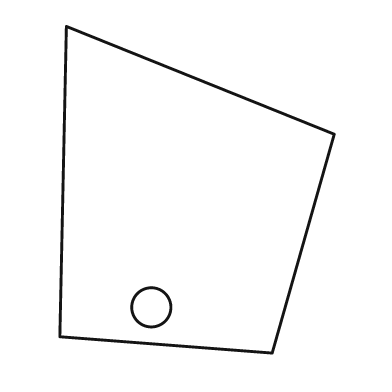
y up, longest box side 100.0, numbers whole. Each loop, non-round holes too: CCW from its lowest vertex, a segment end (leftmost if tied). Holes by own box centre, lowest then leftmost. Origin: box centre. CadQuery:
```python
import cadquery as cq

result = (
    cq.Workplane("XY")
    .moveTo(23.0, -50.0)
    .lineTo(42.0, 17.0)
    .lineTo(-40.0, 50.0)
    .lineTo(-42.0, -45.0)
    .close()
    .moveTo(-14.0, -36.0)
    .circle(6.0)
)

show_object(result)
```